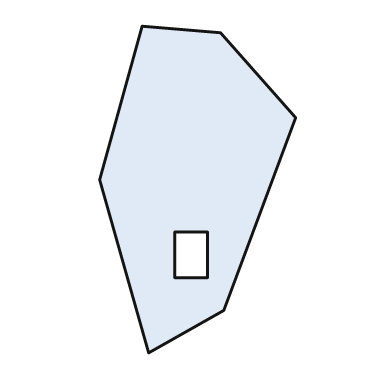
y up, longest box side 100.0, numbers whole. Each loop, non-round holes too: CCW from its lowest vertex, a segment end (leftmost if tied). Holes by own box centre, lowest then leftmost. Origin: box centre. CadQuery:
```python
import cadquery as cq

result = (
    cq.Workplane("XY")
    .moveTo(-15.0, -50.0)
    .lineTo(8.0, -37.0)
    .lineTo(30.0, 22.0)
    .lineTo(7.0, 48.0)
    .lineTo(-17.0, 50.0)
    .lineTo(-30.0, 3.0)
    .close()
    .moveTo(-7.0, -27.0)
    .lineTo(3.0, -27.0)
    .lineTo(3.0, -13.0)
    .lineTo(-7.0, -13.0)
    .close()
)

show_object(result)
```